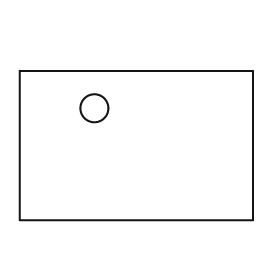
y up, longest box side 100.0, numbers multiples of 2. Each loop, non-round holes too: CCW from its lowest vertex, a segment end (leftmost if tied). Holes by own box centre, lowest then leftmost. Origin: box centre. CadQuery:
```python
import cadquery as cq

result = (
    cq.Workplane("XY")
    .moveTo(-50.0, -32.0)
    .lineTo(50.0, -32.0)
    .lineTo(50.0, 32.0)
    .lineTo(-50.0, 32.0)
    .close()
    .moveTo(-18.0, 16.0)
    .circle(6.0)
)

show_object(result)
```